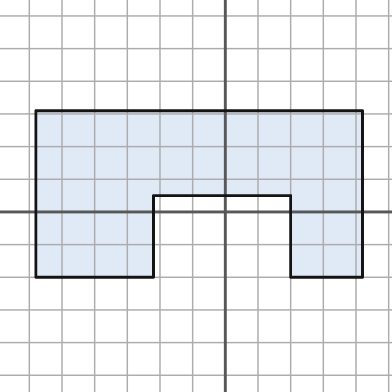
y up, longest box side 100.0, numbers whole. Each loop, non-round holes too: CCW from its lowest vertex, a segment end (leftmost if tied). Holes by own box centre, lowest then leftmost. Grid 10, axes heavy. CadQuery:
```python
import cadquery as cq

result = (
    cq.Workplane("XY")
    .moveTo(-58.0, -20.0)
    .lineTo(-22.0, -20.0)
    .lineTo(-22.0, 5.0)
    .lineTo(20.0, 5.0)
    .lineTo(20.0, -20.0)
    .lineTo(42.0, -20.0)
    .lineTo(42.0, 31.0)
    .lineTo(-58.0, 31.0)
    .close()
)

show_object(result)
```